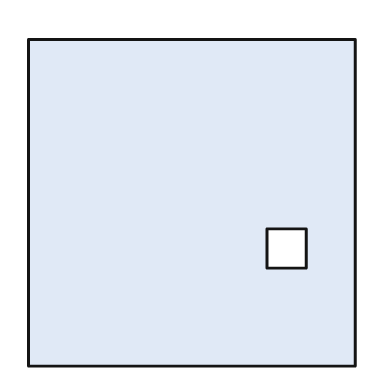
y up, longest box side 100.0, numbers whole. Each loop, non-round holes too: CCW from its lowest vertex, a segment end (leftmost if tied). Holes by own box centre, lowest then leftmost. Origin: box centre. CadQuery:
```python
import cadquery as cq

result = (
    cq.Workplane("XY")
    .moveTo(-50.0, -50.0)
    .lineTo(50.0, -50.0)
    .lineTo(50.0, 50.0)
    .lineTo(-50.0, 50.0)
    .close()
    .moveTo(23.0, -20.0)
    .lineTo(35.0, -20.0)
    .lineTo(35.0, -8.0)
    .lineTo(23.0, -8.0)
    .close()
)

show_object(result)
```